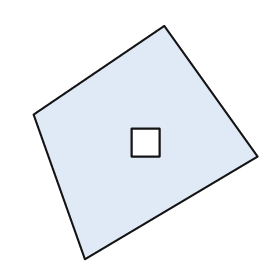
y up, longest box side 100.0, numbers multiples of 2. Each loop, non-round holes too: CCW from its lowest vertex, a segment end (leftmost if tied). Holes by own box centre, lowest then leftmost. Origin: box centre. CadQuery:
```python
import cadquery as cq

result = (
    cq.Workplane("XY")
    .moveTo(-26.0, -50.0)
    .lineTo(48.0, -6.0)
    .lineTo(8.0, 50.0)
    .lineTo(-48.0, 12.0)
    .close()
    .moveTo(-6.0, -6.0)
    .lineTo(6.0, -6.0)
    .lineTo(6.0, 6.0)
    .lineTo(-6.0, 6.0)
    .close()
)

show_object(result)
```